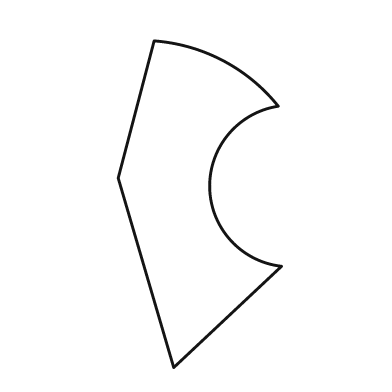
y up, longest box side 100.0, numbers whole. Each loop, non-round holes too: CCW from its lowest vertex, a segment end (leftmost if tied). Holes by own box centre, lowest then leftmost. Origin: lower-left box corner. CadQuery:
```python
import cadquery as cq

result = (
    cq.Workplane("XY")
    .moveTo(17.0, 0.0)
    .lineTo(50.0, 31.0)
    .threePointArc((28.0, 55.0), (49.0, 80.0))
    .threePointArc((32.0, 94.0), (11.0, 100.0))
    .lineTo(0.0, 58.0)
    .close()
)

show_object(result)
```